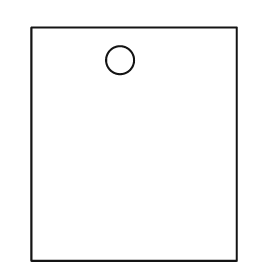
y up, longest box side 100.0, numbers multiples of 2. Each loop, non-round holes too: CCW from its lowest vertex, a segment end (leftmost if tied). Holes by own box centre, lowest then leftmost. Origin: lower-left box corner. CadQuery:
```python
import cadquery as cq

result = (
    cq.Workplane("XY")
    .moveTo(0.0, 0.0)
    .lineTo(88.0, 0.0)
    .lineTo(88.0, 100.0)
    .lineTo(0.0, 100.0)
    .close()
    .moveTo(38.0, 86.0)
    .circle(6.0)
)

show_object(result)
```